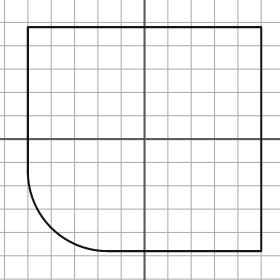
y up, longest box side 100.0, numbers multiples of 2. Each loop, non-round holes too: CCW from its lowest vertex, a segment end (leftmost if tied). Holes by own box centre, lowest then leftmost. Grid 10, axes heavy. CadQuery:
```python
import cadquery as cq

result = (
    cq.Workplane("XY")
    .moveTo(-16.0, -48.0)
    .lineTo(50.0, -48.0)
    .lineTo(50.0, 48.0)
    .lineTo(-50.0, 48.0)
    .lineTo(-50.0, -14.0)
    .threePointArc((-40.0, -38.0), (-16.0, -48.0))
    .close()
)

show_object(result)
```